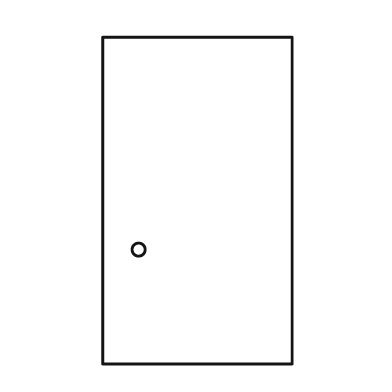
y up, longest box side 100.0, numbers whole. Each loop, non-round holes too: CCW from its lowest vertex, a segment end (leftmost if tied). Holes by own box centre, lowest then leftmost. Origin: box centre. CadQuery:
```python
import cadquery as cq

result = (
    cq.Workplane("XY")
    .moveTo(-29.0, -50.0)
    .lineTo(29.0, -50.0)
    .lineTo(29.0, 50.0)
    .lineTo(-29.0, 50.0)
    .close()
    .moveTo(-18.0, -15.0)
    .circle(2.0)
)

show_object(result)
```